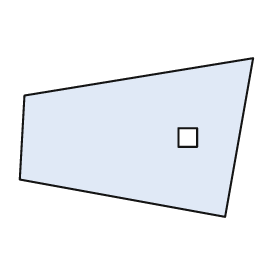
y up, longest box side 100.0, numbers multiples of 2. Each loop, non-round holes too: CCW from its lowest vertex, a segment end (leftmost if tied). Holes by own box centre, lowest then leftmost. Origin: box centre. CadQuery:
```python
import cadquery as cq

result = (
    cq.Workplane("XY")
    .moveTo(38.0, -34.0)
    .lineTo(50.0, 34.0)
    .lineTo(-48.0, 18.0)
    .lineTo(-50.0, -18.0)
    .close()
    .moveTo(18.0, -4.0)
    .lineTo(26.0, -4.0)
    .lineTo(26.0, 4.0)
    .lineTo(18.0, 4.0)
    .close()
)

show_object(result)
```